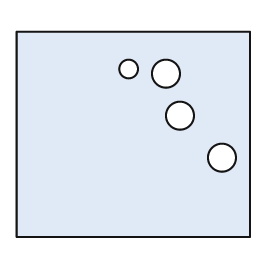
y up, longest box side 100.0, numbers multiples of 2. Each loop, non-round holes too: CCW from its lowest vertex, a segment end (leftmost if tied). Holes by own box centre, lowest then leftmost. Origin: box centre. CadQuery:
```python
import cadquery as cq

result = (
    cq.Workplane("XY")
    .moveTo(-50.0, -44.0)
    .lineTo(50.0, -44.0)
    .lineTo(50.0, 44.0)
    .lineTo(-50.0, 44.0)
    .close()
    .moveTo(38.0, -10.0)
    .circle(6.0)
    .moveTo(20.0, 8.0)
    .circle(6.0)
    .moveTo(14.0, 26.0)
    .circle(6.0)
    .moveTo(-2.0, 28.0)
    .circle(4.0)
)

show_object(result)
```